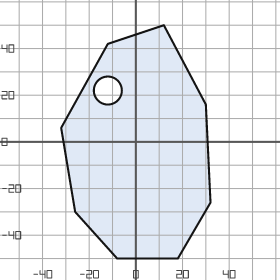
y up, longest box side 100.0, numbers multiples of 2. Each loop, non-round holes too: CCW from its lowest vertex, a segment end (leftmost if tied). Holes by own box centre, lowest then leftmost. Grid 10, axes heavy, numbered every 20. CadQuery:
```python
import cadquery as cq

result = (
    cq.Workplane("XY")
    .moveTo(-8.0, -50.0)
    .lineTo(18.0, -50.0)
    .lineTo(32.0, -26.0)
    .lineTo(30.0, 16.0)
    .lineTo(12.0, 50.0)
    .lineTo(-12.0, 42.0)
    .lineTo(-32.0, 6.0)
    .lineTo(-26.0, -30.0)
    .close()
    .moveTo(-12.0, 22.0)
    .circle(6.0)
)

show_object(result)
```